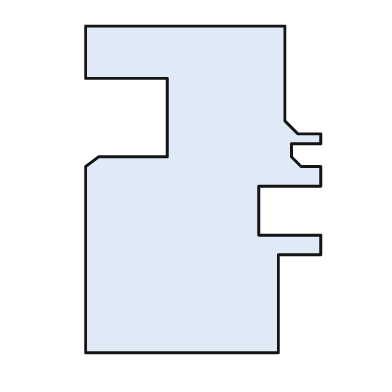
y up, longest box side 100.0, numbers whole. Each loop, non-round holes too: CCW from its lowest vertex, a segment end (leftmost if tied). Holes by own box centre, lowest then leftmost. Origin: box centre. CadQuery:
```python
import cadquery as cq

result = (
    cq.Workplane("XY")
    .moveTo(-36.0, -50.0)
    .lineTo(23.0, -50.0)
    .lineTo(23.0, -20.0)
    .lineTo(36.0, -20.0)
    .lineTo(36.0, -14.0)
    .lineTo(17.0, -14.0)
    .lineTo(17.0, 1.0)
    .lineTo(36.0, 1.0)
    .lineTo(36.0, 7.0)
    .lineTo(30.0, 7.0)
    .lineTo(27.0, 10.0)
    .lineTo(27.0, 14.0)
    .lineTo(36.0, 14.0)
    .lineTo(36.0, 17.0)
    .lineTo(29.0, 17.0)
    .lineTo(25.0, 21.0)
    .lineTo(25.0, 50.0)
    .lineTo(-36.0, 50.0)
    .lineTo(-36.0, 34.0)
    .lineTo(-11.0, 34.0)
    .lineTo(-11.0, 10.0)
    .lineTo(-32.0, 10.0)
    .lineTo(-36.0, 7.0)
    .close()
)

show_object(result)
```